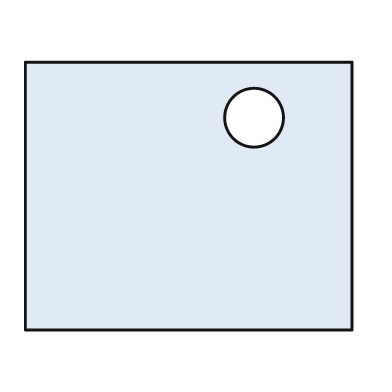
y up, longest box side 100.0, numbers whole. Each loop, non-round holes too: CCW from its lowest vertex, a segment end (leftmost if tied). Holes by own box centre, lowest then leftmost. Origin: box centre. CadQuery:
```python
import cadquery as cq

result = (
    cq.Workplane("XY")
    .moveTo(-50.0, -41.0)
    .lineTo(50.0, -41.0)
    .lineTo(50.0, 41.0)
    .lineTo(-50.0, 41.0)
    .close()
    .moveTo(20.0, 24.0)
    .circle(9.0)
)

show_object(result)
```